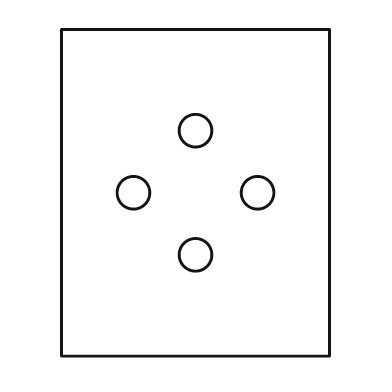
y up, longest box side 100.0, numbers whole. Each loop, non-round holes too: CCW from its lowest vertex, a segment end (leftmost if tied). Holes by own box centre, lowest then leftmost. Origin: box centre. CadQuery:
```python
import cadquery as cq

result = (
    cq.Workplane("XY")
    .moveTo(-41.0, -50.0)
    .lineTo(41.0, -50.0)
    .lineTo(41.0, 50.0)
    .lineTo(-41.0, 50.0)
    .close()
    .moveTo(0.0, -19.0)
    .circle(5.0)
    .moveTo(-19.0, 0.0)
    .circle(5.0)
    .moveTo(19.0, 0.0)
    .circle(5.0)
    .moveTo(0.0, 19.0)
    .circle(5.0)
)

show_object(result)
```